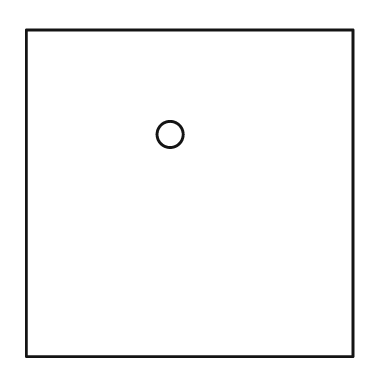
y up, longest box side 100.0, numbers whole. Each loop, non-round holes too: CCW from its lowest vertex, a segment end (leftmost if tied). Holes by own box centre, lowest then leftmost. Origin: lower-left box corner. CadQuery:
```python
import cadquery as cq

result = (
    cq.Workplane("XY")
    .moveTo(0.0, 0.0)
    .lineTo(100.0, 0.0)
    .lineTo(100.0, 100.0)
    .lineTo(0.0, 100.0)
    .close()
    .moveTo(44.0, 68.0)
    .circle(4.0)
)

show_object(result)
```